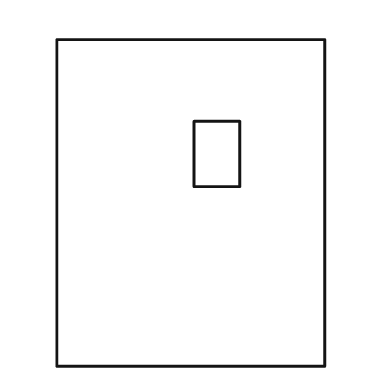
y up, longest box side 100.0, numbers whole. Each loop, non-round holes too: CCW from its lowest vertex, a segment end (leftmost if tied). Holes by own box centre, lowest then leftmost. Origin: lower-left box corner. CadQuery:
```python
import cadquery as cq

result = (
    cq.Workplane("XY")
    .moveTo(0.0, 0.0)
    .lineTo(82.0, 0.0)
    .lineTo(82.0, 100.0)
    .lineTo(0.0, 100.0)
    .close()
    .moveTo(42.0, 55.0)
    .lineTo(56.0, 55.0)
    .lineTo(56.0, 75.0)
    .lineTo(42.0, 75.0)
    .close()
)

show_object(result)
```